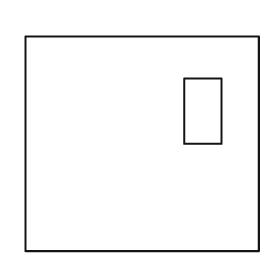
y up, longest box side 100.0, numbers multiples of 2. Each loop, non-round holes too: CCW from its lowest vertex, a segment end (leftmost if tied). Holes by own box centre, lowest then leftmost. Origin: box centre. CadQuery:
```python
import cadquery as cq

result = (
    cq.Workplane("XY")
    .moveTo(-50.0, -46.0)
    .lineTo(50.0, -46.0)
    .lineTo(50.0, 46.0)
    .lineTo(-50.0, 46.0)
    .close()
    .moveTo(18.0, 0.0)
    .lineTo(34.0, 0.0)
    .lineTo(34.0, 28.0)
    .lineTo(18.0, 28.0)
    .close()
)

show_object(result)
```